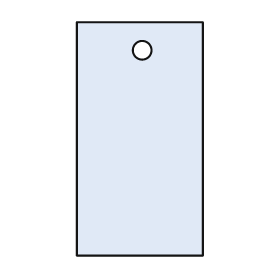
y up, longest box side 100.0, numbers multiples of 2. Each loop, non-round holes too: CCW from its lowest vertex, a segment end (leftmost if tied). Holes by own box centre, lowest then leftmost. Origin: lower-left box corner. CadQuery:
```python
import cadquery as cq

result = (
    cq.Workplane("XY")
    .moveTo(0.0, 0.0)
    .lineTo(54.0, 0.0)
    .lineTo(54.0, 100.0)
    .lineTo(0.0, 100.0)
    .close()
    .moveTo(28.0, 88.0)
    .circle(4.0)
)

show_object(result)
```